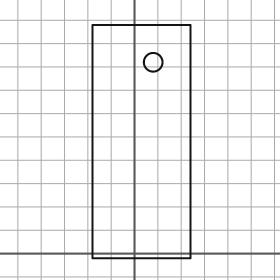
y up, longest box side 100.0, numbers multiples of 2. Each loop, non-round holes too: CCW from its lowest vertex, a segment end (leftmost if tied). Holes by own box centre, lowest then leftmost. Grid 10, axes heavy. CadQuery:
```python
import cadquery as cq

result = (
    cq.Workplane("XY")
    .moveTo(-18.0, -2.0)
    .lineTo(24.0, -2.0)
    .lineTo(24.0, 98.0)
    .lineTo(-18.0, 98.0)
    .close()
    .moveTo(8.0, 82.0)
    .circle(4.0)
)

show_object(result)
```